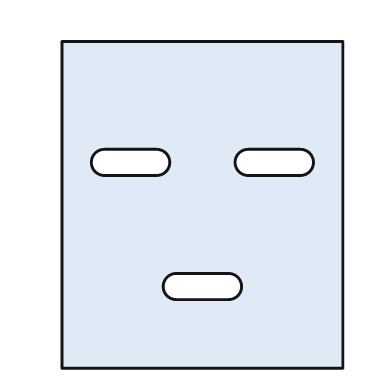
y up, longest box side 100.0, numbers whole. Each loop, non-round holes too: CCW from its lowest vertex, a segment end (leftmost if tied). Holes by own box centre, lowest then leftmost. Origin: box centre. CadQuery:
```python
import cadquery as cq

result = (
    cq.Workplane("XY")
    .moveTo(-43.0, -50.0)
    .lineTo(43.0, -50.0)
    .lineTo(43.0, 50.0)
    .lineTo(-43.0, 50.0)
    .close()
    .moveTo(-8.0, -29.0)
    .lineTo(8.0, -29.0)
    .threePointArc((12.0, -25.0), (8.0, -21.0))
    .lineTo(-8.0, -21.0)
    .threePointArc((-12.0, -25.0), (-8.0, -29.0))
    .close()
    .moveTo(-30.0, 9.0)
    .lineTo(-14.0, 9.0)
    .threePointArc((-10.0, 13.0), (-14.0, 17.0))
    .lineTo(-30.0, 17.0)
    .threePointArc((-34.0, 13.0), (-30.0, 9.0))
    .close()
    .moveTo(14.0, 9.0)
    .lineTo(30.0, 9.0)
    .threePointArc((34.0, 13.0), (30.0, 17.0))
    .lineTo(14.0, 17.0)
    .threePointArc((10.0, 13.0), (14.0, 9.0))
    .close()
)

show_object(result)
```